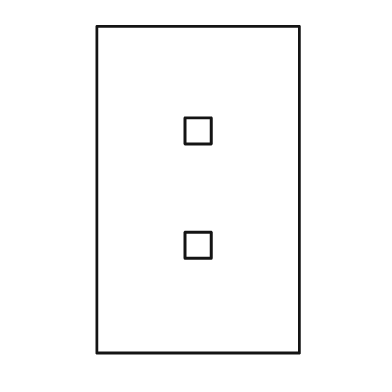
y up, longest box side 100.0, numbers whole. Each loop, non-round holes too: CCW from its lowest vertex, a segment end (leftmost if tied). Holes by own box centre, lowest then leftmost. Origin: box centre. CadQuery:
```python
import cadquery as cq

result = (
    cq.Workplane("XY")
    .moveTo(-31.0, -50.0)
    .lineTo(31.0, -50.0)
    .lineTo(31.0, 50.0)
    .lineTo(-31.0, 50.0)
    .close()
    .moveTo(-4.0, -21.0)
    .lineTo(4.0, -21.0)
    .lineTo(4.0, -13.0)
    .lineTo(-4.0, -13.0)
    .close()
    .moveTo(-4.0, 14.0)
    .lineTo(4.0, 14.0)
    .lineTo(4.0, 22.0)
    .lineTo(-4.0, 22.0)
    .close()
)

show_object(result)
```